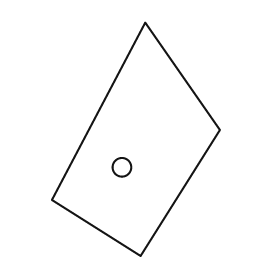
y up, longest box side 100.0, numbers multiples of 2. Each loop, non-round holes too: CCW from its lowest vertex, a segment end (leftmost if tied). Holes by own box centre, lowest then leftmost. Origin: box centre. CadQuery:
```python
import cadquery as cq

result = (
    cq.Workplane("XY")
    .moveTo(2.0, -50.0)
    .lineTo(36.0, 4.0)
    .lineTo(4.0, 50.0)
    .lineTo(-36.0, -26.0)
    .close()
    .moveTo(-6.0, -12.0)
    .circle(4.0)
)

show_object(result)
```